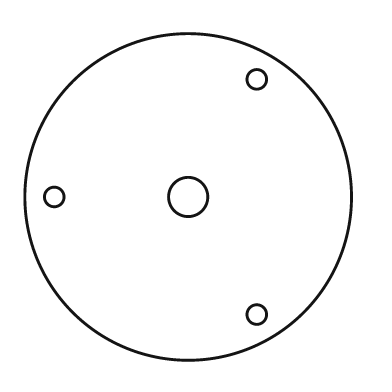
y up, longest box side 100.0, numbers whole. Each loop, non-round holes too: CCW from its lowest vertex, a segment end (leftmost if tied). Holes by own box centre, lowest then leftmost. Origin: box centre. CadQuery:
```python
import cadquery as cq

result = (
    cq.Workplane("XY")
    .moveTo(0.0, 0.0)
    .circle(50.0)
    .moveTo(21.0, -36.0)
    .circle(3.0)
    .moveTo(-41.0, 0.0)
    .circle(3.0)
    .moveTo(0.0, 0.0)
    .circle(6.0)
    .moveTo(21.0, 36.0)
    .circle(3.0)
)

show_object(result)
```